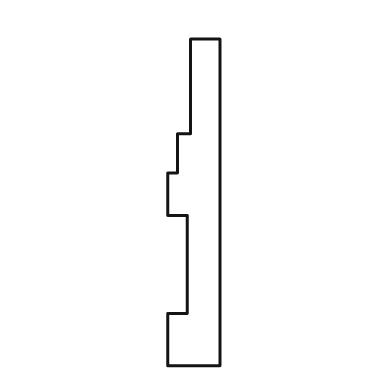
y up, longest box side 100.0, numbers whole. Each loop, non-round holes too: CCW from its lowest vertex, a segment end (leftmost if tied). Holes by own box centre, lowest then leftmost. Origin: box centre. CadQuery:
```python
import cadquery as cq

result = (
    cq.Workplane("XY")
    .moveTo(-8.0, -50.0)
    .lineTo(8.0, -50.0)
    .lineTo(8.0, 50.0)
    .lineTo(-1.0, 50.0)
    .lineTo(-1.0, 21.0)
    .lineTo(-5.0, 21.0)
    .lineTo(-5.0, 9.0)
    .lineTo(-8.0, 9.0)
    .lineTo(-8.0, -4.0)
    .lineTo(-2.0, -4.0)
    .lineTo(-2.0, -34.0)
    .lineTo(-8.0, -34.0)
    .close()
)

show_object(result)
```